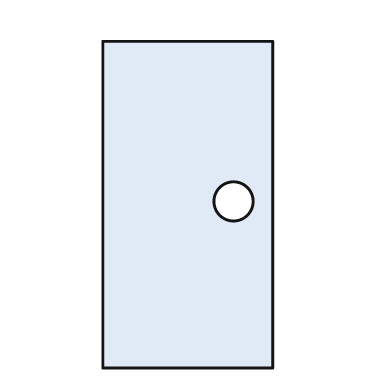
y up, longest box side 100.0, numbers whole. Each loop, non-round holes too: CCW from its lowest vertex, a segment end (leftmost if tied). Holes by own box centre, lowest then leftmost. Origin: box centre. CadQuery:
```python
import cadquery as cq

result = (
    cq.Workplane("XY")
    .moveTo(-26.0, -50.0)
    .lineTo(26.0, -50.0)
    .lineTo(26.0, 50.0)
    .lineTo(-26.0, 50.0)
    .close()
    .moveTo(14.0, 1.0)
    .circle(6.0)
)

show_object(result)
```